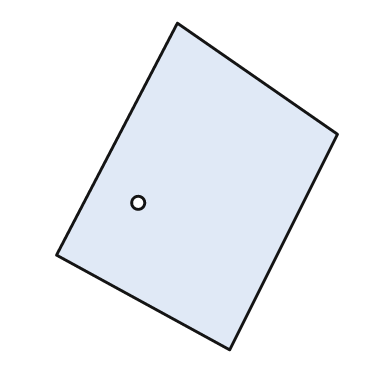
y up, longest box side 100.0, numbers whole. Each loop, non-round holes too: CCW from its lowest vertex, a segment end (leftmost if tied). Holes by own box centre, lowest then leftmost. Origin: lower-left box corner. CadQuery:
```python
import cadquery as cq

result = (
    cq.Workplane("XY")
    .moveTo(53.0, 0.0)
    .lineTo(86.0, 66.0)
    .lineTo(37.0, 100.0)
    .lineTo(0.0, 29.0)
    .close()
    .moveTo(25.0, 45.0)
    .circle(2.0)
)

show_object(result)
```